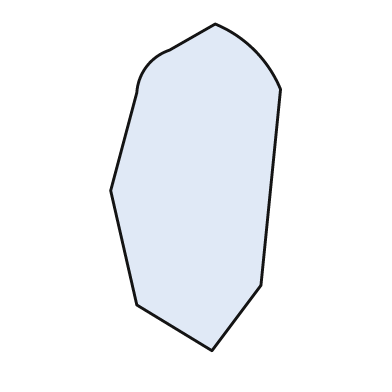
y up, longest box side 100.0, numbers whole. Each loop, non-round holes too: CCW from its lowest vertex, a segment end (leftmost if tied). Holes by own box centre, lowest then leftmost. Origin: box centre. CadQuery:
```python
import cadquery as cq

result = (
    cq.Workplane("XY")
    .moveTo(5.0, -50.0)
    .lineTo(20.0, -30.0)
    .lineTo(26.0, 30.0)
    .threePointArc((18.0, 42.0), (6.0, 50.0))
    .lineTo(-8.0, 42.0)
    .threePointArc((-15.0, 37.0), (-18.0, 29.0))
    .lineTo(-26.0, -1.0)
    .lineTo(-18.0, -36.0)
    .close()
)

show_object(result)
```